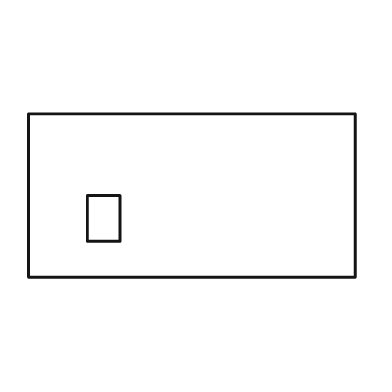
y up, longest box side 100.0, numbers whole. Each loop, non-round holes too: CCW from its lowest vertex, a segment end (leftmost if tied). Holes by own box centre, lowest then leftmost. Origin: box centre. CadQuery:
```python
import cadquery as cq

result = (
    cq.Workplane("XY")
    .moveTo(-50.0, -25.0)
    .lineTo(50.0, -25.0)
    .lineTo(50.0, 25.0)
    .lineTo(-50.0, 25.0)
    .close()
    .moveTo(-32.0, -14.0)
    .lineTo(-22.0, -14.0)
    .lineTo(-22.0, 0.0)
    .lineTo(-32.0, 0.0)
    .close()
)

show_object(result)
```